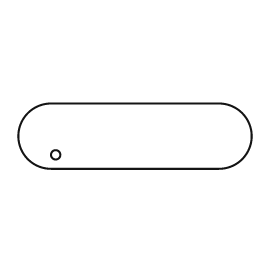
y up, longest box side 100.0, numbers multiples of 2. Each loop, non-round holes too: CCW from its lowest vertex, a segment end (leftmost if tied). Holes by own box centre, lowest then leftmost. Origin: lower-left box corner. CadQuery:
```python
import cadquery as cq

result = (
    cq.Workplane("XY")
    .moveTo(14.0, 0.0)
    .lineTo(86.0, 0.0)
    .threePointArc((100.0, 14.0), (86.0, 28.0))
    .lineTo(14.0, 28.0)
    .threePointArc((0.0, 14.0), (14.0, 0.0))
    .close()
    .moveTo(16.0, 6.0)
    .circle(2.0)
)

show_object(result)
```